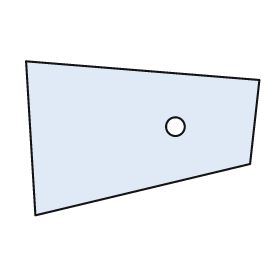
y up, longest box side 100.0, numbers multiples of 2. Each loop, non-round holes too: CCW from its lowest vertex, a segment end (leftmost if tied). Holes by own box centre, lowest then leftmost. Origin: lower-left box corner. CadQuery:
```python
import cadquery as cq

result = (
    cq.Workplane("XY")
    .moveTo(4.0, 0.0)
    .lineTo(96.0, 22.0)
    .lineTo(100.0, 58.0)
    .lineTo(0.0, 66.0)
    .close()
    .moveTo(64.0, 38.0)
    .circle(4.0)
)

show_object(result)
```